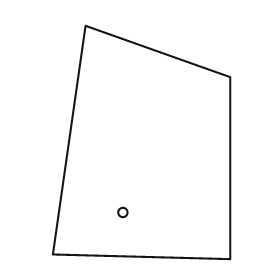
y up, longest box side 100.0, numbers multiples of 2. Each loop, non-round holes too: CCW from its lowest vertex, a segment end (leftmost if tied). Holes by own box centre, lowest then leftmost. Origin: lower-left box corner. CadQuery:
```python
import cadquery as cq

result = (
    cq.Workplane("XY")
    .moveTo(76.0, 0.0)
    .lineTo(76.0, 78.0)
    .lineTo(14.0, 100.0)
    .lineTo(0.0, 2.0)
    .close()
    .moveTo(30.0, 20.0)
    .circle(2.0)
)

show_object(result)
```